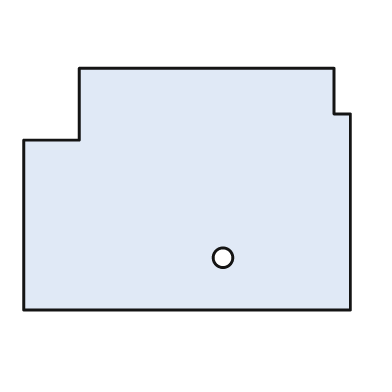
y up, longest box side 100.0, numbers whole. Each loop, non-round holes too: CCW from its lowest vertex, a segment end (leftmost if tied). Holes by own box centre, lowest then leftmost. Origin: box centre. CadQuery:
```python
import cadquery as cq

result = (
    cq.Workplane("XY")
    .moveTo(-50.0, -37.0)
    .lineTo(50.0, -37.0)
    .lineTo(50.0, 23.0)
    .lineTo(45.0, 23.0)
    .lineTo(45.0, 37.0)
    .lineTo(-33.0, 37.0)
    .lineTo(-33.0, 15.0)
    .lineTo(-50.0, 15.0)
    .close()
    .moveTo(11.0, -21.0)
    .circle(3.0)
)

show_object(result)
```